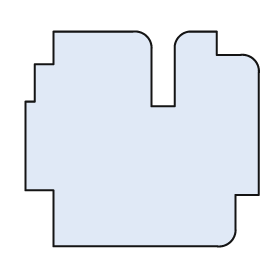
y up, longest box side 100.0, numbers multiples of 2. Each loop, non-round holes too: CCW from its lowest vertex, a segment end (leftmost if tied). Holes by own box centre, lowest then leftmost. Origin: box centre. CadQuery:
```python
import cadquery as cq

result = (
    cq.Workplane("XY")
    .moveTo(-38.0, -46.0)
    .lineTo(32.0, -46.0)
    .threePointArc((38.0, -44.0), (40.0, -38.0))
    .lineTo(40.0, -24.0)
    .lineTo(50.0, -24.0)
    .lineTo(50.0, 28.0)
    .threePointArc((48.0, 34.0), (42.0, 36.0))
    .lineTo(32.0, 36.0)
    .lineTo(32.0, 46.0)
    .lineTo(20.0, 46.0)
    .threePointArc((16.0, 44.0), (14.0, 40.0))
    .lineTo(14.0, 14.0)
    .lineTo(4.0, 14.0)
    .lineTo(4.0, 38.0)
    .threePointArc((2.0, 44.0), (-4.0, 46.0))
    .lineTo(-38.0, 46.0)
    .lineTo(-38.0, 32.0)
    .lineTo(-46.0, 32.0)
    .lineTo(-46.0, 16.0)
    .lineTo(-50.0, 16.0)
    .lineTo(-50.0, -22.0)
    .lineTo(-38.0, -22.0)
    .close()
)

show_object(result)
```